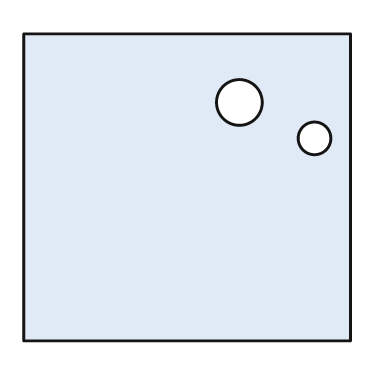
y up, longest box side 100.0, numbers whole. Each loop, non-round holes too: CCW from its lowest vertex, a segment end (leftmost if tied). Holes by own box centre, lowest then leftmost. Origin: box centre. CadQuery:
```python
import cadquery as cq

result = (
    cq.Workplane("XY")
    .moveTo(-50.0, -47.0)
    .lineTo(50.0, -47.0)
    .lineTo(50.0, 47.0)
    .lineTo(-50.0, 47.0)
    .close()
    .moveTo(39.0, 15.0)
    .circle(5.0)
    .moveTo(16.0, 26.0)
    .circle(7.0)
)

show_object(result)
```